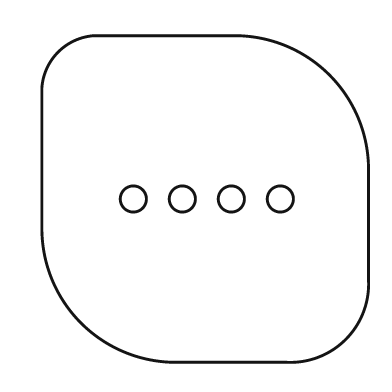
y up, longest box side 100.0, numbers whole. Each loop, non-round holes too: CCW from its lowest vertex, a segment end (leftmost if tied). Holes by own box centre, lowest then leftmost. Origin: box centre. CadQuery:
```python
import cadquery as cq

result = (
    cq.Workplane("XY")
    .moveTo(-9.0, -50.0)
    .lineTo(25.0, -50.0)
    .threePointArc((43.0, -43.0), (50.0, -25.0))
    .lineTo(50.0, 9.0)
    .threePointArc((38.0, 38.0), (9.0, 50.0))
    .lineTo(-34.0, 50.0)
    .threePointArc((-45.0, 45.0), (-50.0, 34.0))
    .lineTo(-50.0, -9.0)
    .threePointArc((-38.0, -38.0), (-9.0, -50.0))
    .close()
    .moveTo(-22.0, 0.0)
    .circle(4.0)
    .moveTo(-7.0, 0.0)
    .circle(4.0)
    .moveTo(8.0, 0.0)
    .circle(4.0)
    .moveTo(23.0, 0.0)
    .circle(4.0)
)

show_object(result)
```